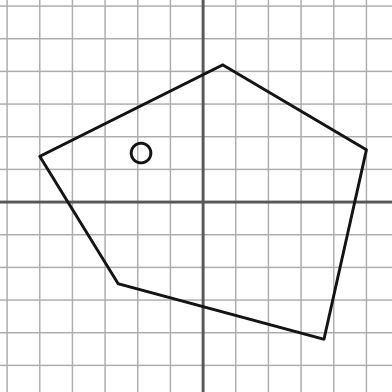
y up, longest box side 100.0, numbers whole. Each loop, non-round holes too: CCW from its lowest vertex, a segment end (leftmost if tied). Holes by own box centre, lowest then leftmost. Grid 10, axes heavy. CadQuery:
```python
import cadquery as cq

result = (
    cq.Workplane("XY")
    .moveTo(37.0, -42.0)
    .lineTo(50.0, 16.0)
    .lineTo(6.0, 42.0)
    .lineTo(-50.0, 14.0)
    .lineTo(-26.0, -25.0)
    .close()
    .moveTo(-19.0, 15.0)
    .circle(3.0)
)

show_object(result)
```